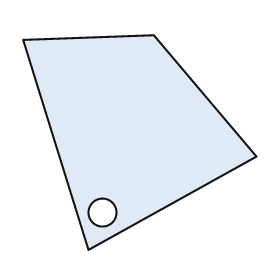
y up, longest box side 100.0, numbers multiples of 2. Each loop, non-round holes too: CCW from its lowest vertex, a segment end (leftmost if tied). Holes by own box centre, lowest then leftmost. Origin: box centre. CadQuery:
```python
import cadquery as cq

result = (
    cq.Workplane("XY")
    .moveTo(-22.0, -46.0)
    .lineTo(50.0, -6.0)
    .lineTo(6.0, 46.0)
    .lineTo(-50.0, 44.0)
    .close()
    .moveTo(-16.0, -30.0)
    .circle(6.0)
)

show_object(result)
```